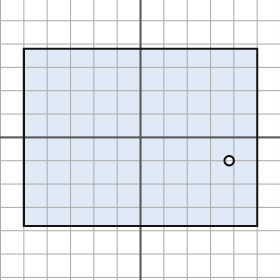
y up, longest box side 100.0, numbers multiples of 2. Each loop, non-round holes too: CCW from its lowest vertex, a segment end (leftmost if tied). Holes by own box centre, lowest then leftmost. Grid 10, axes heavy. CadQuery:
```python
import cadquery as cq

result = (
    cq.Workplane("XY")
    .moveTo(-50.0, -38.0)
    .lineTo(50.0, -38.0)
    .lineTo(50.0, 38.0)
    .lineTo(-50.0, 38.0)
    .close()
    .moveTo(38.0, -10.0)
    .circle(2.0)
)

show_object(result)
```